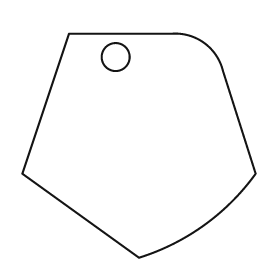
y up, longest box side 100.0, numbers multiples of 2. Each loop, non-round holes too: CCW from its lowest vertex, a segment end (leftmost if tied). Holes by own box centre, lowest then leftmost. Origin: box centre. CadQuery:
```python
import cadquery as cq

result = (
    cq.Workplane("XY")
    .moveTo(0.0, -48.0)
    .threePointArc((28.0, -34.0), (50.0, -12.0))
    .lineTo(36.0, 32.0)
    .threePointArc((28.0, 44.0), (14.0, 48.0))
    .lineTo(-30.0, 48.0)
    .lineTo(-50.0, -12.0)
    .close()
    .moveTo(-10.0, 38.0)
    .circle(6.0)
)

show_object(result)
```